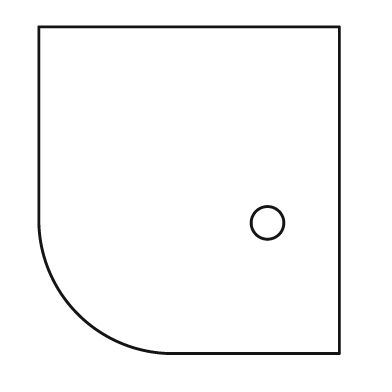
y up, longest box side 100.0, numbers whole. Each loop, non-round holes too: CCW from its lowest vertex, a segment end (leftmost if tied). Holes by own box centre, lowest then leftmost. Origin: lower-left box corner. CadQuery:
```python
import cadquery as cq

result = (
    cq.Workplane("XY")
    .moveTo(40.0, 0.0)
    .lineTo(92.0, 0.0)
    .lineTo(92.0, 100.0)
    .lineTo(0.0, 100.0)
    .lineTo(0.0, 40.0)
    .threePointArc((12.0, 12.0), (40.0, 0.0))
    .close()
    .moveTo(70.0, 40.0)
    .circle(5.0)
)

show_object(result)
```